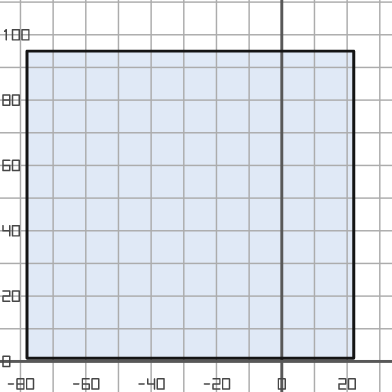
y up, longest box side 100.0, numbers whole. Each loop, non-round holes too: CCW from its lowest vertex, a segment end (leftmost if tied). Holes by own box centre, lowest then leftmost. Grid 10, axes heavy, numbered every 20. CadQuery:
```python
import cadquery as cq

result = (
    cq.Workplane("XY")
    .moveTo(-78.0, 1.0)
    .lineTo(22.0, 1.0)
    .lineTo(22.0, 95.0)
    .lineTo(-78.0, 95.0)
    .close()
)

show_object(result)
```